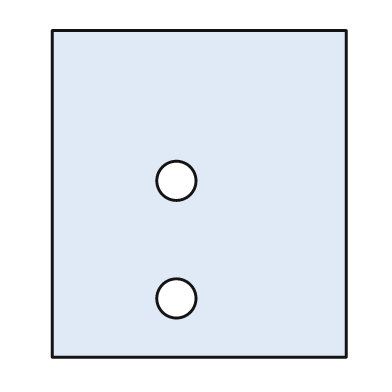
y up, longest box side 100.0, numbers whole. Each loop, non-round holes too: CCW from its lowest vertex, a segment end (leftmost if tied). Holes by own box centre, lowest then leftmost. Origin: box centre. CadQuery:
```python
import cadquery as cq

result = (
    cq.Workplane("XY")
    .moveTo(-45.0, -50.0)
    .lineTo(45.0, -50.0)
    .lineTo(45.0, 50.0)
    .lineTo(-45.0, 50.0)
    .close()
    .moveTo(-7.0, -32.0)
    .circle(6.0)
    .moveTo(-7.0, 4.0)
    .circle(6.0)
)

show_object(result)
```